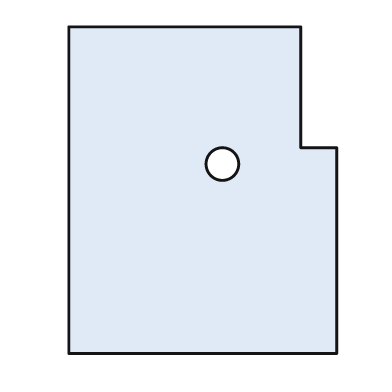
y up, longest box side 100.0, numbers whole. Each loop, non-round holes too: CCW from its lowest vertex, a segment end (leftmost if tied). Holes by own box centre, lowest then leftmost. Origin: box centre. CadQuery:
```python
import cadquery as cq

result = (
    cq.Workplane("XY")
    .moveTo(-41.0, -50.0)
    .lineTo(41.0, -50.0)
    .lineTo(41.0, 13.0)
    .lineTo(30.0, 13.0)
    .lineTo(30.0, 50.0)
    .lineTo(-41.0, 50.0)
    .close()
    .moveTo(6.0, 8.0)
    .circle(5.0)
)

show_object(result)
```